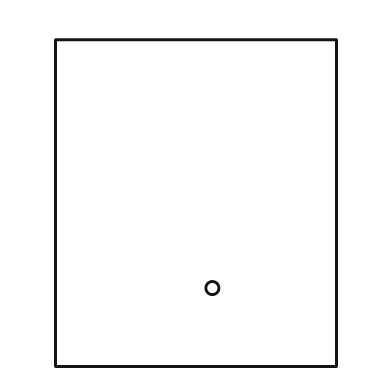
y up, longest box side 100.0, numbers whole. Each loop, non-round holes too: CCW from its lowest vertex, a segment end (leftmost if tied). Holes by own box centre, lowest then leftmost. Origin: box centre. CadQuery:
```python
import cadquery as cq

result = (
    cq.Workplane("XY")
    .moveTo(-43.0, -50.0)
    .lineTo(43.0, -50.0)
    .lineTo(43.0, 50.0)
    .lineTo(-43.0, 50.0)
    .close()
    .moveTo(5.0, -26.0)
    .circle(2.0)
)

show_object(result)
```